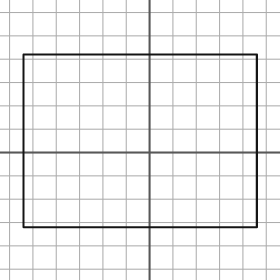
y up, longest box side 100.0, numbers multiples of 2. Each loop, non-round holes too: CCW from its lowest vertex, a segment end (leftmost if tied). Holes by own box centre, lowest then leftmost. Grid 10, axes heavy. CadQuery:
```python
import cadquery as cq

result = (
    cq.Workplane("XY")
    .moveTo(-54.0, -32.0)
    .lineTo(46.0, -32.0)
    .lineTo(46.0, 42.0)
    .lineTo(-54.0, 42.0)
    .close()
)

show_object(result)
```